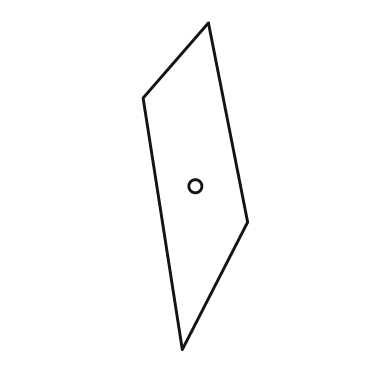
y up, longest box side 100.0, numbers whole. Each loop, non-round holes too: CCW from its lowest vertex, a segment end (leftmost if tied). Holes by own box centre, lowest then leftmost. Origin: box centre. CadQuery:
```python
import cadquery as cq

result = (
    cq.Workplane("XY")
    .moveTo(-4.0, -50.0)
    .lineTo(16.0, -11.0)
    .lineTo(4.0, 50.0)
    .lineTo(-16.0, 27.0)
    .close()
    .moveTo(0.0, 0.0)
    .circle(2.0)
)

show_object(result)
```